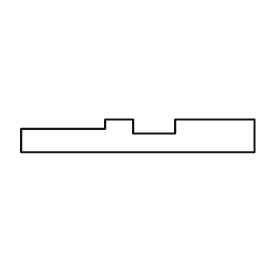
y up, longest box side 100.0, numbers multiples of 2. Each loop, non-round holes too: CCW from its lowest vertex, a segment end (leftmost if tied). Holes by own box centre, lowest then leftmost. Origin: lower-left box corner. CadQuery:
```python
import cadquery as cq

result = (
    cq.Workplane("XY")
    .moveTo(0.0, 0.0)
    .lineTo(100.0, 0.0)
    .lineTo(100.0, 14.0)
    .lineTo(66.0, 14.0)
    .lineTo(66.0, 8.0)
    .lineTo(48.0, 8.0)
    .lineTo(48.0, 14.0)
    .lineTo(36.0, 14.0)
    .lineTo(36.0, 10.0)
    .lineTo(0.0, 10.0)
    .close()
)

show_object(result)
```